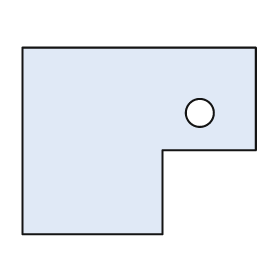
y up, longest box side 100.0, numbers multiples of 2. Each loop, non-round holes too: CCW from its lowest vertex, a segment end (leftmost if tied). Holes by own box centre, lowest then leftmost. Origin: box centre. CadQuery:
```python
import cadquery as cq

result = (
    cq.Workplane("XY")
    .moveTo(-50.0, -40.0)
    .lineTo(10.0, -40.0)
    .lineTo(10.0, -4.0)
    .lineTo(50.0, -4.0)
    .lineTo(50.0, 40.0)
    .lineTo(-50.0, 40.0)
    .close()
    .moveTo(26.0, 12.0)
    .circle(6.0)
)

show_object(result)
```